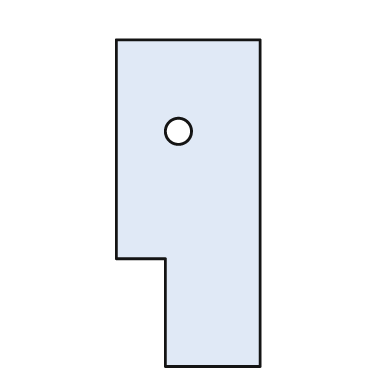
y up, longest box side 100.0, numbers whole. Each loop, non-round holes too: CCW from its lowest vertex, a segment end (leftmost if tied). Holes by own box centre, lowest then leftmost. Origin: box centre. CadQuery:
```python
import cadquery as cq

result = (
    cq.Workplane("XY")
    .moveTo(-7.0, -50.0)
    .lineTo(22.0, -50.0)
    .lineTo(22.0, 50.0)
    .lineTo(-22.0, 50.0)
    .lineTo(-22.0, -17.0)
    .lineTo(-7.0, -17.0)
    .close()
    .moveTo(-3.0, 22.0)
    .circle(4.0)
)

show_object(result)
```